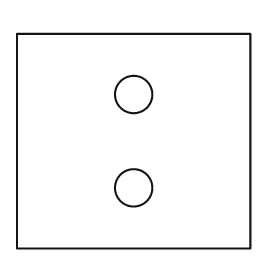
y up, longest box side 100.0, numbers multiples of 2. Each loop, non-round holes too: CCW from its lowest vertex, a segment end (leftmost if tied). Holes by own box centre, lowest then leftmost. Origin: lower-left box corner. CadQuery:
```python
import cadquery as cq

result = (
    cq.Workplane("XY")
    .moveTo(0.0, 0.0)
    .lineTo(100.0, 0.0)
    .lineTo(100.0, 92.0)
    .lineTo(0.0, 92.0)
    .close()
    .moveTo(50.0, 26.0)
    .circle(8.0)
    .moveTo(50.0, 66.0)
    .circle(8.0)
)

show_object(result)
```